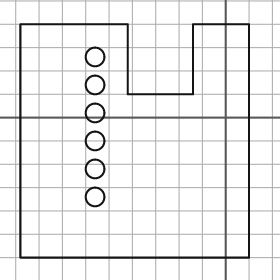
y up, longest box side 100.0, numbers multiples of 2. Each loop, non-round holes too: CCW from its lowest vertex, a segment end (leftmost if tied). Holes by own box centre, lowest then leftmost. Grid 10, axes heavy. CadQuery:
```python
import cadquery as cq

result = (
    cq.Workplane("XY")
    .moveTo(-88.0, -60.0)
    .lineTo(10.0, -60.0)
    .lineTo(10.0, 40.0)
    .lineTo(-14.0, 40.0)
    .lineTo(-14.0, 10.0)
    .lineTo(-42.0, 10.0)
    .lineTo(-42.0, 40.0)
    .lineTo(-88.0, 40.0)
    .close()
    .moveTo(-56.0, -34.0)
    .circle(4.0)
    .moveTo(-56.0, -22.0)
    .circle(4.0)
    .moveTo(-56.0, -10.0)
    .circle(4.0)
    .moveTo(-56.0, 2.0)
    .circle(4.0)
    .moveTo(-56.0, 14.0)
    .circle(4.0)
    .moveTo(-56.0, 26.0)
    .circle(4.0)
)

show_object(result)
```